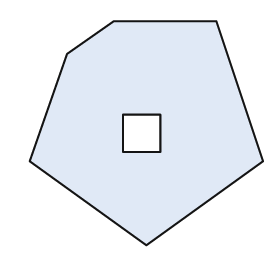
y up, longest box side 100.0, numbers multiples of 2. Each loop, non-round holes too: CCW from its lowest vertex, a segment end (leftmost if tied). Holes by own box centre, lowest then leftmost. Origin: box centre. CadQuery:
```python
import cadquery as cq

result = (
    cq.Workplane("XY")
    .moveTo(0.0, -48.0)
    .lineTo(50.0, -12.0)
    .lineTo(30.0, 48.0)
    .lineTo(-14.0, 48.0)
    .lineTo(-34.0, 34.0)
    .lineTo(-50.0, -12.0)
    .close()
    .moveTo(-10.0, -8.0)
    .lineTo(6.0, -8.0)
    .lineTo(6.0, 8.0)
    .lineTo(-10.0, 8.0)
    .close()
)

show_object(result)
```